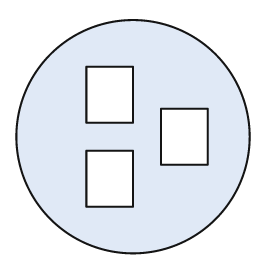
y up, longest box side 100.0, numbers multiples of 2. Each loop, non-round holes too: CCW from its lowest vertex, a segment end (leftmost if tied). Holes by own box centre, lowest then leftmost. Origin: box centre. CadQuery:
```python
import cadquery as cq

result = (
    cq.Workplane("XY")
    .moveTo(0.0, 0.0)
    .circle(50.0)
    .moveTo(-20.0, -30.0)
    .lineTo(0.0, -30.0)
    .lineTo(0.0, -6.0)
    .lineTo(-20.0, -6.0)
    .close()
    .moveTo(12.0, -12.0)
    .lineTo(32.0, -12.0)
    .lineTo(32.0, 12.0)
    .lineTo(12.0, 12.0)
    .close()
    .moveTo(-20.0, 6.0)
    .lineTo(0.0, 6.0)
    .lineTo(0.0, 30.0)
    .lineTo(-20.0, 30.0)
    .close()
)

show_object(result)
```